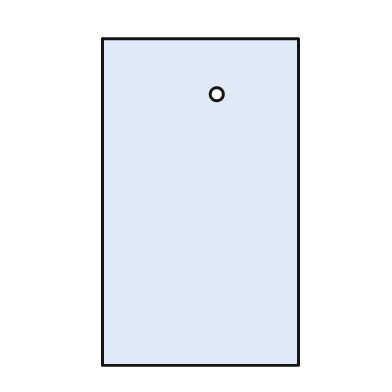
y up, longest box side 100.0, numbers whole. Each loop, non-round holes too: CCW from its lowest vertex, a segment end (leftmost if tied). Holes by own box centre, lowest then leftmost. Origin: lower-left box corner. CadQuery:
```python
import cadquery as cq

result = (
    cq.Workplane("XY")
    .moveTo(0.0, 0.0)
    .lineTo(60.0, 0.0)
    .lineTo(60.0, 100.0)
    .lineTo(0.0, 100.0)
    .close()
    .moveTo(35.0, 83.0)
    .circle(2.0)
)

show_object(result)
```